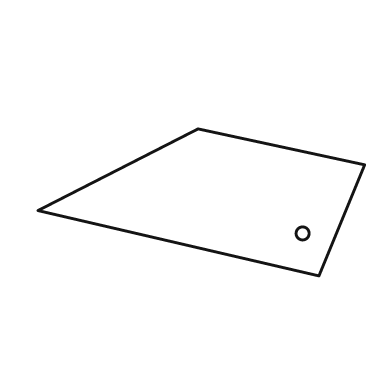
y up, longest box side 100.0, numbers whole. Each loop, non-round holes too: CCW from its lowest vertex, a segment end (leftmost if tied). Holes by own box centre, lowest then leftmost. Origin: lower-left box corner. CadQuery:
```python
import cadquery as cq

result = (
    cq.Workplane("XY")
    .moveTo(86.0, 0.0)
    .lineTo(100.0, 34.0)
    .lineTo(49.0, 45.0)
    .lineTo(0.0, 20.0)
    .close()
    .moveTo(81.0, 13.0)
    .circle(2.0)
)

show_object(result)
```